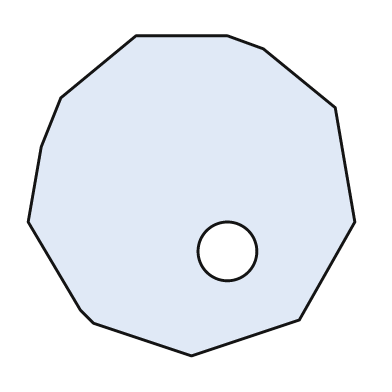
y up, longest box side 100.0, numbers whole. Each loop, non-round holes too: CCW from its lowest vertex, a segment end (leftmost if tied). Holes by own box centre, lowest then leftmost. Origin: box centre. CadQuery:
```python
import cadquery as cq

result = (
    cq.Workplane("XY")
    .moveTo(0.0, -49.0)
    .lineTo(33.0, -38.0)
    .lineTo(50.0, -8.0)
    .lineTo(44.0, 27.0)
    .lineTo(22.0, 45.0)
    .lineTo(11.0, 49.0)
    .lineTo(-17.0, 49.0)
    .lineTo(-40.0, 30.0)
    .lineTo(-46.0, 15.0)
    .lineTo(-50.0, -8.0)
    .lineTo(-34.0, -35.0)
    .lineTo(-30.0, -39.0)
    .close()
    .moveTo(11.0, -17.0)
    .circle(9.0)
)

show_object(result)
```